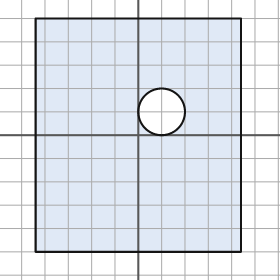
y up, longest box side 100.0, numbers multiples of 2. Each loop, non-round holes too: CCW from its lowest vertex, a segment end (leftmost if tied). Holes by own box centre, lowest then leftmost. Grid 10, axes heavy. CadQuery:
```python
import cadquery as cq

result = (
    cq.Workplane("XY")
    .moveTo(-44.0, -50.0)
    .lineTo(44.0, -50.0)
    .lineTo(44.0, 50.0)
    .lineTo(-44.0, 50.0)
    .close()
    .moveTo(10.0, 10.0)
    .circle(10.0)
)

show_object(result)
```